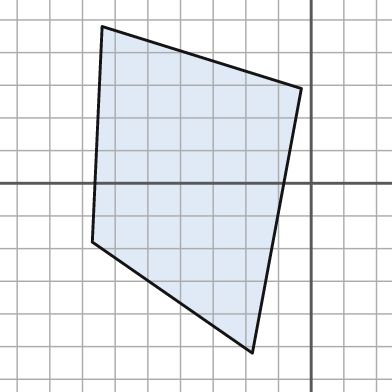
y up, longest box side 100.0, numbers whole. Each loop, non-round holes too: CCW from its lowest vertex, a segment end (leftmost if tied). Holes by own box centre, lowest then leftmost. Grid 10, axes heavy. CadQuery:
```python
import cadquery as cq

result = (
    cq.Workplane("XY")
    .moveTo(-18.0, -52.0)
    .lineTo(-3.0, 29.0)
    .lineTo(-64.0, 48.0)
    .lineTo(-67.0, -18.0)
    .close()
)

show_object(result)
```